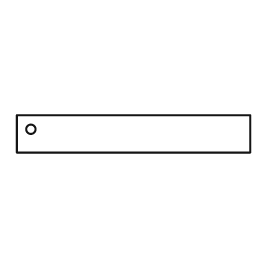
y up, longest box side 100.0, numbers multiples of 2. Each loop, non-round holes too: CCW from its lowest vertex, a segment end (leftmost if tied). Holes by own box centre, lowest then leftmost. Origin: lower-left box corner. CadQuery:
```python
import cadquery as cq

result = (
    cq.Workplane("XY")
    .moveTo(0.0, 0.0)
    .lineTo(100.0, 0.0)
    .lineTo(100.0, 16.0)
    .lineTo(0.0, 16.0)
    .close()
    .moveTo(6.0, 10.0)
    .circle(2.0)
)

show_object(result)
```